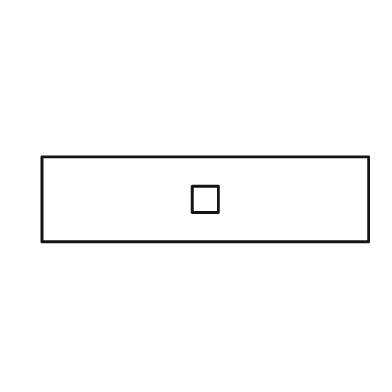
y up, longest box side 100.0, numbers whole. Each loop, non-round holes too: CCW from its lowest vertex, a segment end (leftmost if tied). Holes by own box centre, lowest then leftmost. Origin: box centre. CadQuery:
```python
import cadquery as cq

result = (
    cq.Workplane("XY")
    .moveTo(-50.0, -13.0)
    .lineTo(50.0, -13.0)
    .lineTo(50.0, 13.0)
    .lineTo(-50.0, 13.0)
    .close()
    .moveTo(-4.0, -4.0)
    .lineTo(4.0, -4.0)
    .lineTo(4.0, 4.0)
    .lineTo(-4.0, 4.0)
    .close()
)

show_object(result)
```